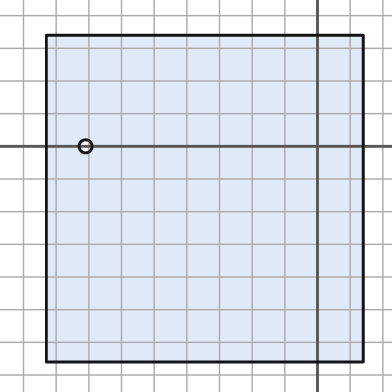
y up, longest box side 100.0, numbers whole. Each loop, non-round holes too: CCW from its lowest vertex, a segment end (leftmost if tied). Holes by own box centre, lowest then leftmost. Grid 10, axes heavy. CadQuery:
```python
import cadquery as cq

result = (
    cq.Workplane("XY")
    .moveTo(-83.0, -66.0)
    .lineTo(14.0, -66.0)
    .lineTo(14.0, 34.0)
    .lineTo(-83.0, 34.0)
    .close()
    .moveTo(-71.0, 0.0)
    .circle(2.0)
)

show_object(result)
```